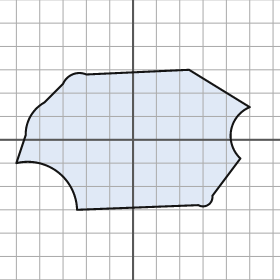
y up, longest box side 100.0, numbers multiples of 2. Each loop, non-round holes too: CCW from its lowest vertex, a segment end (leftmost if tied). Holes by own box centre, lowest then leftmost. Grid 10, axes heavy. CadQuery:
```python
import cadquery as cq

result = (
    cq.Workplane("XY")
    .moveTo(-24.0, -30.0)
    .lineTo(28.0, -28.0)
    .threePointArc((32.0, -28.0), (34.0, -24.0))
    .lineTo(46.0, -8.0)
    .threePointArc((42.0, 4.0), (50.0, 14.0))
    .lineTo(24.0, 30.0)
    .lineTo(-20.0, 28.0)
    .threePointArc((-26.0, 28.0), (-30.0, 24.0))
    .lineTo(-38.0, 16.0)
    .threePointArc((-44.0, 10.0), (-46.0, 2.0))
    .lineTo(-50.0, -10.0)
    .threePointArc((-32.0, -14.0), (-24.0, -30.0))
    .close()
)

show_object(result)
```